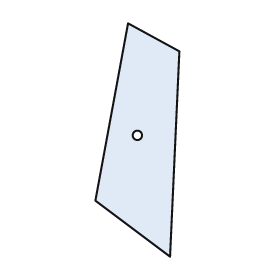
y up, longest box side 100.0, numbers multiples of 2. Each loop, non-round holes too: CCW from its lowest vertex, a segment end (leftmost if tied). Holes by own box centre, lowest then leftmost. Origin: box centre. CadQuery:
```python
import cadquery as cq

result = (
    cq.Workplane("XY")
    .moveTo(14.0, -50.0)
    .lineTo(18.0, 38.0)
    .lineTo(-4.0, 50.0)
    .lineTo(-18.0, -26.0)
    .close()
    .moveTo(0.0, 2.0)
    .circle(2.0)
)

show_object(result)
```